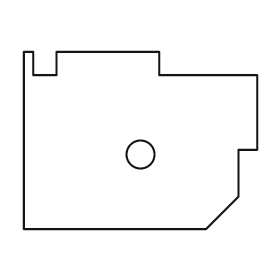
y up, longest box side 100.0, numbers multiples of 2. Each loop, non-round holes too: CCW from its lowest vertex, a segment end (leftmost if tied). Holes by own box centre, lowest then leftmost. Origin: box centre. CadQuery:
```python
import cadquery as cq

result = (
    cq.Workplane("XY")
    .moveTo(-50.0, -38.0)
    .lineTo(28.0, -38.0)
    .lineTo(42.0, -24.0)
    .lineTo(42.0, -4.0)
    .lineTo(50.0, -4.0)
    .lineTo(50.0, 28.0)
    .lineTo(8.0, 28.0)
    .lineTo(8.0, 38.0)
    .lineTo(-36.0, 38.0)
    .lineTo(-36.0, 28.0)
    .lineTo(-46.0, 28.0)
    .lineTo(-46.0, 38.0)
    .lineTo(-50.0, 38.0)
    .close()
    .moveTo(0.0, -6.0)
    .circle(6.0)
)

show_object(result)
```